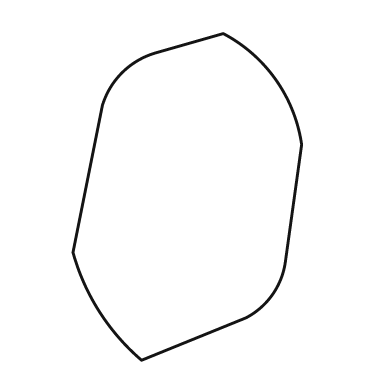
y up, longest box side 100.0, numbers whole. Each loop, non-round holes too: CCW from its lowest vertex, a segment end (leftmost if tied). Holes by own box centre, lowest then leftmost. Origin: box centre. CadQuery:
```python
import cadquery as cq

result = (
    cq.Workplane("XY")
    .moveTo(-14.0, -50.0)
    .lineTo(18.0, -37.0)
    .threePointArc((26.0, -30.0), (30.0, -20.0))
    .lineTo(35.0, 16.0)
    .threePointArc((27.0, 36.0), (11.0, 50.0))
    .lineTo(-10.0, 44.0)
    .threePointArc((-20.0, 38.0), (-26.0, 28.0))
    .lineTo(-35.0, -17.0)
    .threePointArc((-27.0, -35.0), (-14.0, -50.0))
    .close()
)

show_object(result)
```